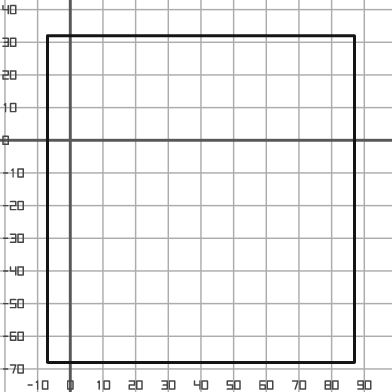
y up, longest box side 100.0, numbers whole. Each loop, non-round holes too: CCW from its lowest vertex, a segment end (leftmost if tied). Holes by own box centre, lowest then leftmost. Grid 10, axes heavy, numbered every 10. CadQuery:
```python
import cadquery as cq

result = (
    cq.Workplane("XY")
    .moveTo(-7.0, -68.0)
    .lineTo(87.0, -68.0)
    .lineTo(87.0, 32.0)
    .lineTo(-7.0, 32.0)
    .close()
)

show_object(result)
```